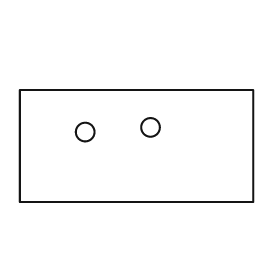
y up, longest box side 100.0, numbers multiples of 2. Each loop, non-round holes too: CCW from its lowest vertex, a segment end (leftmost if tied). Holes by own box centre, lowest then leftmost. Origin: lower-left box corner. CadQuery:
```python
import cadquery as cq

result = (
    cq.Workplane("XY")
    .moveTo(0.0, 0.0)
    .lineTo(100.0, 0.0)
    .lineTo(100.0, 48.0)
    .lineTo(0.0, 48.0)
    .close()
    .moveTo(28.0, 30.0)
    .circle(4.0)
    .moveTo(56.0, 32.0)
    .circle(4.0)
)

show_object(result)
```